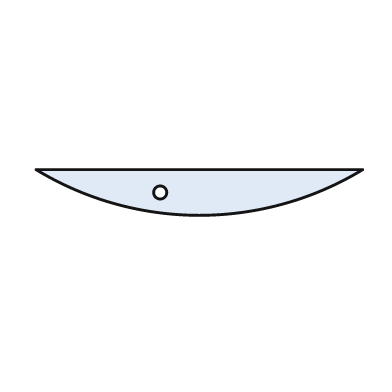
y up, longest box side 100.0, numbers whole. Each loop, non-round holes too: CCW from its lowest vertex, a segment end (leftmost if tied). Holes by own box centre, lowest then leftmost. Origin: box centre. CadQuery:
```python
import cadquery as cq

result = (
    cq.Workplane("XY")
    .moveTo(-50.0, 7.0)
    .threePointArc((0.0, -7.0), (50.0, 7.0))
    .close()
    .moveTo(-12.0, 0.0)
    .circle(2.0)
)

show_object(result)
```